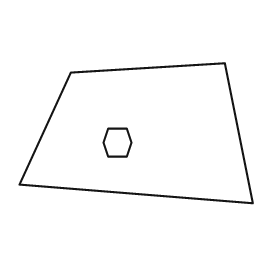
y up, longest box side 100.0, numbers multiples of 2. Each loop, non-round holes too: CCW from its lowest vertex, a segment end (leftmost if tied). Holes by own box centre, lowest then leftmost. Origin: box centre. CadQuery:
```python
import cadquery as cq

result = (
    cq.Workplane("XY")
    .moveTo(50.0, -30.0)
    .lineTo(38.0, 30.0)
    .lineTo(-28.0, 26.0)
    .lineTo(-50.0, -22.0)
    .close()
    .moveTo(-12.0, -10.0)
    .lineTo(-4.0, -10.0)
    .lineTo(-2.0, -4.0)
    .lineTo(-4.0, 2.0)
    .lineTo(-12.0, 2.0)
    .lineTo(-14.0, -4.0)
    .close()
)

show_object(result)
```